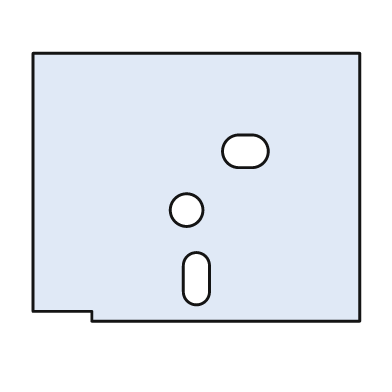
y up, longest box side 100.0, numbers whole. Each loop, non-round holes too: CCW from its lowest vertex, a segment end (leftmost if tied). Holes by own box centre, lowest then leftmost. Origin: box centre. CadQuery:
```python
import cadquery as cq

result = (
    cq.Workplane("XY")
    .moveTo(-32.0, -41.0)
    .lineTo(50.0, -41.0)
    .lineTo(50.0, 41.0)
    .lineTo(-50.0, 41.0)
    .lineTo(-50.0, -38.0)
    .lineTo(-32.0, -38.0)
    .close()
    .moveTo(-4.0, -32.0)
    .threePointArc((0.0, -36.0), (4.0, -32.0))
    .lineTo(4.0, -24.0)
    .threePointArc((0.0, -20.0), (-4.0, -24.0))
    .close()
    .moveTo(-3.0, -7.0)
    .circle(5.0)
    .moveTo(13.0, 6.0)
    .lineTo(17.0, 6.0)
    .threePointArc((22.0, 11.0), (17.0, 16.0))
    .lineTo(13.0, 16.0)
    .threePointArc((8.0, 11.0), (13.0, 6.0))
    .close()
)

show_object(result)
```